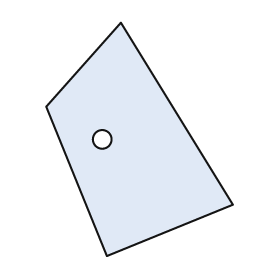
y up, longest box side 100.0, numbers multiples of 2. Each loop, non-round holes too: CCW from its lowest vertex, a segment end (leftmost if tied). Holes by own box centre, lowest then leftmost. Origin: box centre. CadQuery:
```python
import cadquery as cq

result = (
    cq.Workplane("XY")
    .moveTo(-14.0, -50.0)
    .lineTo(40.0, -28.0)
    .lineTo(-8.0, 50.0)
    .lineTo(-40.0, 14.0)
    .close()
    .moveTo(-16.0, 0.0)
    .circle(4.0)
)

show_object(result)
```